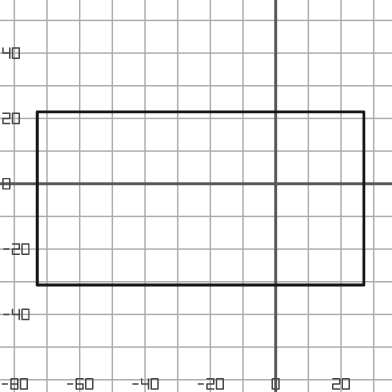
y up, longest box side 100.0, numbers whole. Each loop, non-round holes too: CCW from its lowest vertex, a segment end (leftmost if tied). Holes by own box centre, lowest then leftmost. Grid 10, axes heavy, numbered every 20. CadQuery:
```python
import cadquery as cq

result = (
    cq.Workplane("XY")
    .moveTo(-73.0, -31.0)
    .lineTo(27.0, -31.0)
    .lineTo(27.0, 22.0)
    .lineTo(-73.0, 22.0)
    .close()
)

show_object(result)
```